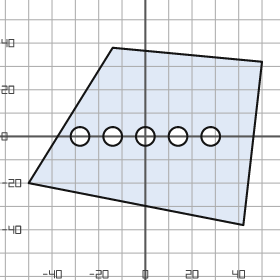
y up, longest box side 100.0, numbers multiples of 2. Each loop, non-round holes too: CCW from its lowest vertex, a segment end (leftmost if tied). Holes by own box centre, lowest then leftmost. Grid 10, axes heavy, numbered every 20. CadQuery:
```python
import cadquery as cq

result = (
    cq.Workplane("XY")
    .moveTo(42.0, -38.0)
    .lineTo(50.0, 32.0)
    .lineTo(-14.0, 38.0)
    .lineTo(-50.0, -20.0)
    .close()
    .moveTo(-28.0, 0.0)
    .circle(4.0)
    .moveTo(-14.0, 0.0)
    .circle(4.0)
    .moveTo(0.0, 0.0)
    .circle(4.0)
    .moveTo(14.0, 0.0)
    .circle(4.0)
    .moveTo(28.0, 0.0)
    .circle(4.0)
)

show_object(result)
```